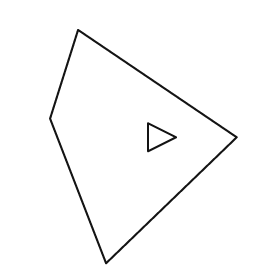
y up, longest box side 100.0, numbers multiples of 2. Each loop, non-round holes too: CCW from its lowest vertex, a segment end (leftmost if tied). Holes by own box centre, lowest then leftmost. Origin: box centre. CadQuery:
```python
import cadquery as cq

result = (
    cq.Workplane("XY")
    .moveTo(-16.0, -50.0)
    .lineTo(40.0, 4.0)
    .lineTo(-28.0, 50.0)
    .lineTo(-40.0, 12.0)
    .close()
    .moveTo(2.0, -2.0)
    .lineTo(14.0, 4.0)
    .lineTo(2.0, 10.0)
    .close()
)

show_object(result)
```